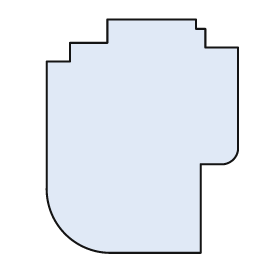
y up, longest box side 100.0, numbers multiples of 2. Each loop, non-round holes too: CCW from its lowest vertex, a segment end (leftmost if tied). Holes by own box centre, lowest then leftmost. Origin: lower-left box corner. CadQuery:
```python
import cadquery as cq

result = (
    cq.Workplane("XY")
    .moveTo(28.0, 0.0)
    .lineTo(66.0, 0.0)
    .lineTo(66.0, 38.0)
    .lineTo(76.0, 38.0)
    .threePointArc((80.0, 40.0), (82.0, 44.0))
    .lineTo(82.0, 88.0)
    .lineTo(68.0, 88.0)
    .lineTo(68.0, 96.0)
    .lineTo(64.0, 96.0)
    .lineTo(64.0, 100.0)
    .lineTo(26.0, 100.0)
    .lineTo(26.0, 90.0)
    .lineTo(10.0, 90.0)
    .lineTo(10.0, 82.0)
    .lineTo(0.0, 82.0)
    .lineTo(0.0, 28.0)
    .threePointArc((8.0, 8.0), (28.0, 0.0))
    .close()
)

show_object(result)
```